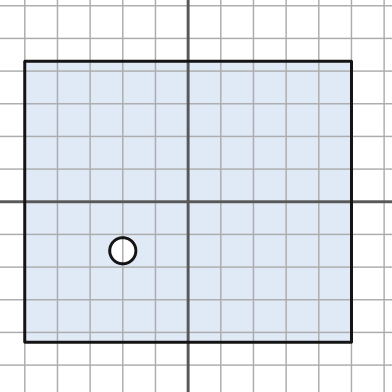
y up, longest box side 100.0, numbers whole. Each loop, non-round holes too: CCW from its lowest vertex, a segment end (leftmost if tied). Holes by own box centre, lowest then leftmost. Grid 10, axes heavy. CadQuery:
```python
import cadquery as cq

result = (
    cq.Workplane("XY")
    .moveTo(-50.0, -43.0)
    .lineTo(50.0, -43.0)
    .lineTo(50.0, 43.0)
    .lineTo(-50.0, 43.0)
    .close()
    .moveTo(-20.0, -15.0)
    .circle(4.0)
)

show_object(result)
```